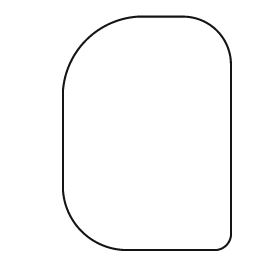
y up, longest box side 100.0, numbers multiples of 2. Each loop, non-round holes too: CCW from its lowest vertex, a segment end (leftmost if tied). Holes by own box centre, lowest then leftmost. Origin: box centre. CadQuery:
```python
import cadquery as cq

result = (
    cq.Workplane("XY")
    .moveTo(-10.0, -50.0)
    .lineTo(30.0, -50.0)
    .threePointArc((34.0, -48.0), (36.0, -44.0))
    .lineTo(36.0, 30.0)
    .threePointArc((30.0, 44.0), (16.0, 50.0))
    .lineTo(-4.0, 50.0)
    .threePointArc((-26.0, 40.0), (-36.0, 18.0))
    .lineTo(-36.0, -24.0)
    .threePointArc((-28.0, -42.0), (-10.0, -50.0))
    .close()
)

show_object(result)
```